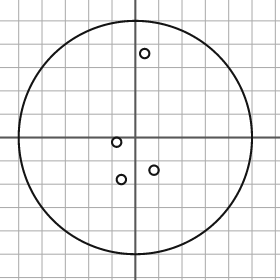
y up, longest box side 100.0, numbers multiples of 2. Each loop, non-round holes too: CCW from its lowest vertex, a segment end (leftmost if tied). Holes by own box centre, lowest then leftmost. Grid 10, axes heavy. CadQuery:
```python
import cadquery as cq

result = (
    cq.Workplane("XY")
    .moveTo(0.0, 0.0)
    .circle(50.0)
    .moveTo(-6.0, -18.0)
    .circle(2.0)
    .moveTo(8.0, -14.0)
    .circle(2.0)
    .moveTo(-8.0, -2.0)
    .circle(2.0)
    .moveTo(4.0, 36.0)
    .circle(2.0)
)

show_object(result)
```